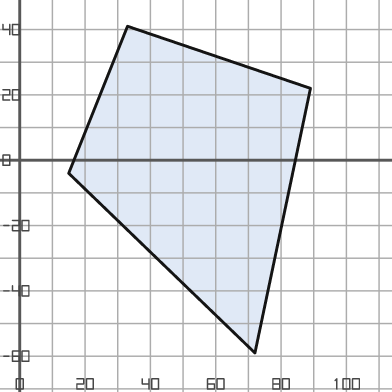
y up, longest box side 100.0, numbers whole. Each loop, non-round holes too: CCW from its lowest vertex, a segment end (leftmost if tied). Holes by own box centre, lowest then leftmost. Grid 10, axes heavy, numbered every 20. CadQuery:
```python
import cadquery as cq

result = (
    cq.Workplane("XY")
    .moveTo(72.0, -59.0)
    .lineTo(89.0, 22.0)
    .lineTo(33.0, 41.0)
    .lineTo(15.0, -4.0)
    .close()
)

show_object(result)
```